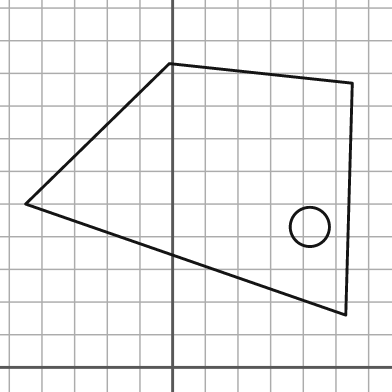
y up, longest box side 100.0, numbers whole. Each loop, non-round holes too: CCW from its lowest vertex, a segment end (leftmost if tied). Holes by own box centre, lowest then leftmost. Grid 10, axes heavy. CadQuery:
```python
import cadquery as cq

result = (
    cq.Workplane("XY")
    .moveTo(53.0, 16.0)
    .lineTo(55.0, 87.0)
    .lineTo(-1.0, 93.0)
    .lineTo(-45.0, 50.0)
    .close()
    .moveTo(42.0, 43.0)
    .circle(6.0)
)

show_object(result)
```